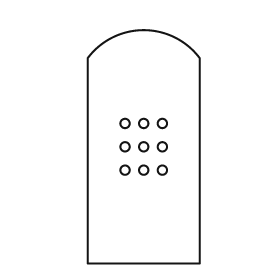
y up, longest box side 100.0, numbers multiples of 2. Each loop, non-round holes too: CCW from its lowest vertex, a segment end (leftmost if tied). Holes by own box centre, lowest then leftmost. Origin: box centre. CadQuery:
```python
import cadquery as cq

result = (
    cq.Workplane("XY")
    .moveTo(-24.0, -50.0)
    .lineTo(24.0, -50.0)
    .lineTo(24.0, 38.0)
    .threePointArc((0.0, 50.0), (-24.0, 38.0))
    .close()
    .moveTo(-8.0, -10.0)
    .circle(2.0)
    .moveTo(0.0, -10.0)
    .circle(2.0)
    .moveTo(8.0, -10.0)
    .circle(2.0)
    .moveTo(-8.0, 0.0)
    .circle(2.0)
    .moveTo(0.0, 0.0)
    .circle(2.0)
    .moveTo(8.0, 0.0)
    .circle(2.0)
    .moveTo(-8.0, 10.0)
    .circle(2.0)
    .moveTo(0.0, 10.0)
    .circle(2.0)
    .moveTo(8.0, 10.0)
    .circle(2.0)
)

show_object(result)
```